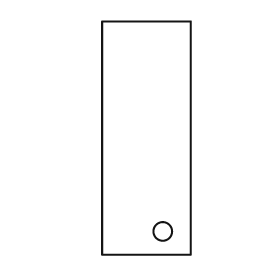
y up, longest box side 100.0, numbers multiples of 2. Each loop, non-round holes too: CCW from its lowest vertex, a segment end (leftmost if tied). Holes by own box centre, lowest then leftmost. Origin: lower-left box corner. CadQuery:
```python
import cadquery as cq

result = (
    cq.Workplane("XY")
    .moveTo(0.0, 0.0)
    .lineTo(38.0, 0.0)
    .lineTo(38.0, 100.0)
    .lineTo(0.0, 100.0)
    .close()
    .moveTo(26.0, 10.0)
    .circle(4.0)
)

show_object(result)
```